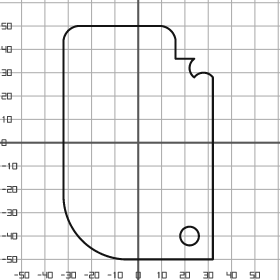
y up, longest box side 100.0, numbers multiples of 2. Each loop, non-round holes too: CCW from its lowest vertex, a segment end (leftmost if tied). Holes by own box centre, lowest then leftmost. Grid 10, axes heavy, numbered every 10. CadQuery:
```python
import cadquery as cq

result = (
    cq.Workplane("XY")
    .moveTo(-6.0, -50.0)
    .lineTo(32.0, -50.0)
    .lineTo(32.0, 28.0)
    .threePointArc((28.0, 30.0), (24.0, 28.0))
    .threePointArc((22.0, 32.0), (24.0, 36.0))
    .lineTo(16.0, 36.0)
    .lineTo(16.0, 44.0)
    .threePointArc((14.0, 48.0), (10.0, 50.0))
    .lineTo(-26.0, 50.0)
    .threePointArc((-30.0, 48.0), (-32.0, 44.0))
    .lineTo(-32.0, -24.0)
    .threePointArc((-24.0, -42.0), (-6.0, -50.0))
    .close()
    .moveTo(22.0, -40.0)
    .circle(4.0)
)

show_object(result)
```